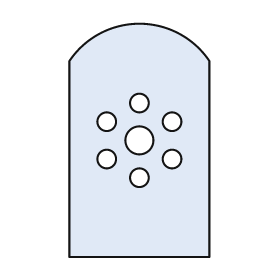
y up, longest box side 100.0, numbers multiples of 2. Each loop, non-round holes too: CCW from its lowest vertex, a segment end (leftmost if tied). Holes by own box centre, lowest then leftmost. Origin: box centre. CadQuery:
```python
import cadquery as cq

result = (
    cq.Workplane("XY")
    .moveTo(-30.0, -50.0)
    .lineTo(30.0, -50.0)
    .lineTo(30.0, 34.0)
    .threePointArc((0.0, 50.0), (-30.0, 34.0))
    .close()
    .moveTo(0.0, -16.0)
    .circle(4.0)
    .moveTo(-14.0, -8.0)
    .circle(4.0)
    .moveTo(14.0, -8.0)
    .circle(4.0)
    .moveTo(0.0, 0.0)
    .circle(6.0)
    .moveTo(-14.0, 8.0)
    .circle(4.0)
    .moveTo(14.0, 8.0)
    .circle(4.0)
    .moveTo(0.0, 16.0)
    .circle(4.0)
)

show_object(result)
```